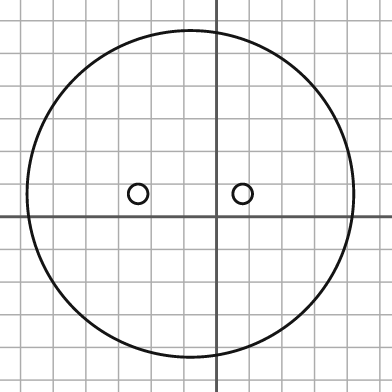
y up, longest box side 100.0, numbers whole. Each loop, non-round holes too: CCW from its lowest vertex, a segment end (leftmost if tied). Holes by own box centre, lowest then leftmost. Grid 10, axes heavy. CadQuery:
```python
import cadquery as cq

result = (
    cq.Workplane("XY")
    .moveTo(-8.0, 7.0)
    .circle(50.0)
    .moveTo(-24.0, 7.0)
    .circle(3.0)
    .moveTo(8.0, 7.0)
    .circle(3.0)
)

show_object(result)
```